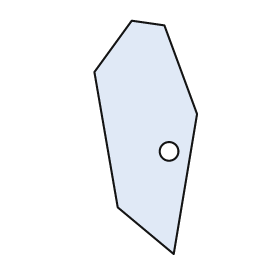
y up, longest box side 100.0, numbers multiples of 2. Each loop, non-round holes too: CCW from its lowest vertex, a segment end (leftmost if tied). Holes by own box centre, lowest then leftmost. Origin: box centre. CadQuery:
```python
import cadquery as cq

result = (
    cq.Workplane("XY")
    .moveTo(12.0, -50.0)
    .lineTo(22.0, 10.0)
    .lineTo(8.0, 48.0)
    .lineTo(-6.0, 50.0)
    .lineTo(-22.0, 28.0)
    .lineTo(-12.0, -30.0)
    .close()
    .moveTo(10.0, -6.0)
    .circle(4.0)
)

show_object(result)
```